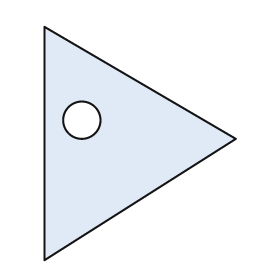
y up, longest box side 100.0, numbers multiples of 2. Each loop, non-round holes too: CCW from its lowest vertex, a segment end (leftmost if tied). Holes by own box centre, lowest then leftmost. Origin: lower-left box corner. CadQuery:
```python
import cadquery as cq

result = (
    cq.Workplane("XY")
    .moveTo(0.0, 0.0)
    .lineTo(82.0, 52.0)
    .lineTo(0.0, 100.0)
    .close()
    .moveTo(16.0, 60.0)
    .circle(8.0)
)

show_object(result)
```